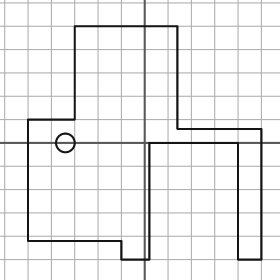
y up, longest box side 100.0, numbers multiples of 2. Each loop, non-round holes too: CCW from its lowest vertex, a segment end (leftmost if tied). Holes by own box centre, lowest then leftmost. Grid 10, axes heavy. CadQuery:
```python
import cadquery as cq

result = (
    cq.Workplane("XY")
    .moveTo(-10.0, -50.0)
    .lineTo(2.0, -50.0)
    .lineTo(2.0, 0.0)
    .lineTo(40.0, 0.0)
    .lineTo(40.0, -50.0)
    .lineTo(50.0, -50.0)
    .lineTo(50.0, 6.0)
    .lineTo(14.0, 6.0)
    .lineTo(14.0, 50.0)
    .lineTo(-30.0, 50.0)
    .lineTo(-30.0, 10.0)
    .lineTo(-50.0, 10.0)
    .lineTo(-50.0, -42.0)
    .lineTo(-10.0, -42.0)
    .close()
    .moveTo(-34.0, 0.0)
    .circle(4.0)
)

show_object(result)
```